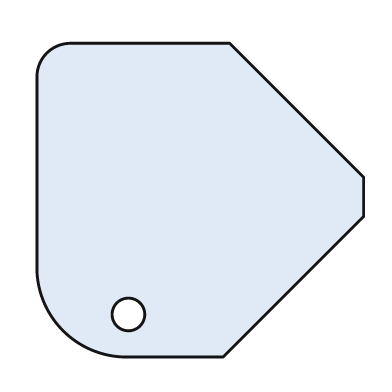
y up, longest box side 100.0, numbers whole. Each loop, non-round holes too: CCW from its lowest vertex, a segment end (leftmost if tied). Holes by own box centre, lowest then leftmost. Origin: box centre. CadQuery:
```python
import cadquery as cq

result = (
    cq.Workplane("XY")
    .moveTo(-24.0, -48.0)
    .lineTo(7.0, -48.0)
    .lineTo(50.0, -5.0)
    .lineTo(50.0, 7.0)
    .lineTo(9.0, 48.0)
    .lineTo(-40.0, 48.0)
    .threePointArc((-47.0, 45.0), (-50.0, 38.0))
    .lineTo(-50.0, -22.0)
    .threePointArc((-42.0, -40.0), (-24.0, -48.0))
    .close()
    .moveTo(-22.0, -35.0)
    .circle(5.0)
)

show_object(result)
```